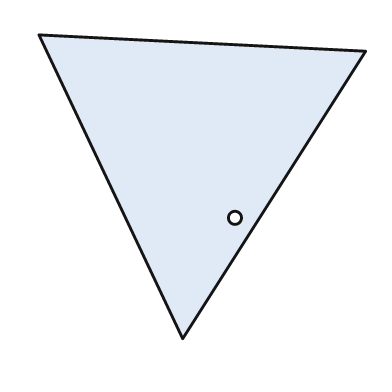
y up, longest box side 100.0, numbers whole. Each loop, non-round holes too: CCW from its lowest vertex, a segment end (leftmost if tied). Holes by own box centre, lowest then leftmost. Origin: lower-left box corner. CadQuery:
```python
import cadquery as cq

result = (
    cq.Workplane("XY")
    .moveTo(44.0, 0.0)
    .lineTo(100.0, 88.0)
    .lineTo(0.0, 93.0)
    .close()
    .moveTo(60.0, 37.0)
    .circle(2.0)
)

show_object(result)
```